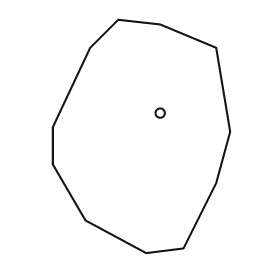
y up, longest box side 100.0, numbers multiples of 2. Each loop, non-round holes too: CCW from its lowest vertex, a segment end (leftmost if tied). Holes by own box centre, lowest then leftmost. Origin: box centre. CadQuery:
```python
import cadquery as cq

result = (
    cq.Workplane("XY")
    .moveTo(2.0, -50.0)
    .lineTo(18.0, -48.0)
    .lineTo(32.0, -20.0)
    .lineTo(38.0, 2.0)
    .lineTo(32.0, 38.0)
    .lineTo(8.0, 48.0)
    .lineTo(-10.0, 50.0)
    .lineTo(-22.0, 38.0)
    .lineTo(-38.0, 4.0)
    .lineTo(-38.0, -12.0)
    .lineTo(-24.0, -36.0)
    .close()
    .moveTo(8.0, 10.0)
    .circle(2.0)
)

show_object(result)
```